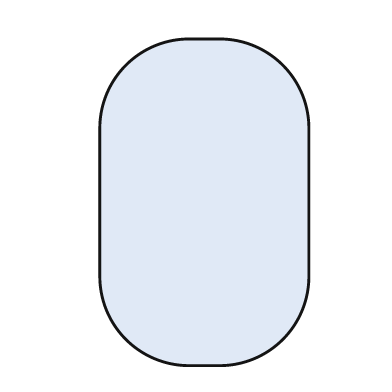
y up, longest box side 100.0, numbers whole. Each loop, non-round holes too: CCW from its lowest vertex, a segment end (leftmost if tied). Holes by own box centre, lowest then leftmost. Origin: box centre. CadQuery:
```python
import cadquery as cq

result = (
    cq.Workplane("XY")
    .moveTo(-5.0, -50.0)
    .lineTo(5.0, -50.0)
    .threePointArc((24.0, -42.0), (32.0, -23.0))
    .lineTo(32.0, 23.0)
    .threePointArc((24.0, 42.0), (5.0, 50.0))
    .lineTo(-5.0, 50.0)
    .threePointArc((-24.0, 42.0), (-32.0, 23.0))
    .lineTo(-32.0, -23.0)
    .threePointArc((-24.0, -42.0), (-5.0, -50.0))
    .close()
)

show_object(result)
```